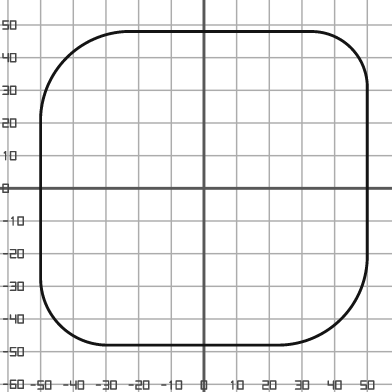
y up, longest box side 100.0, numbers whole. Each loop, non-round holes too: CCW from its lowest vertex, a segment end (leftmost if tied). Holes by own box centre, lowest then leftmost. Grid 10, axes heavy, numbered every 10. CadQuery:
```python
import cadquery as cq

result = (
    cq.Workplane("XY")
    .moveTo(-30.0, -48.0)
    .lineTo(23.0, -48.0)
    .threePointArc((42.0, -40.0), (50.0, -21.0))
    .lineTo(50.0, 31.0)
    .threePointArc((45.0, 43.0), (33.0, 48.0))
    .lineTo(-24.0, 48.0)
    .threePointArc((-42.0, 40.0), (-50.0, 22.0))
    .lineTo(-50.0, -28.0)
    .threePointArc((-44.0, -42.0), (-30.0, -48.0))
    .close()
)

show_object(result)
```